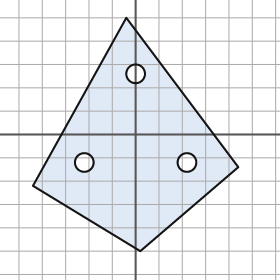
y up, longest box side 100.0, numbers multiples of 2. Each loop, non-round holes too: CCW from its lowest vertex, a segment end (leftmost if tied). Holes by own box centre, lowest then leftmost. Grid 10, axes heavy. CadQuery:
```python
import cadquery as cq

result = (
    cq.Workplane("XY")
    .moveTo(2.0, -50.0)
    .lineTo(44.0, -14.0)
    .lineTo(-4.0, 50.0)
    .lineTo(-44.0, -22.0)
    .close()
    .moveTo(-22.0, -12.0)
    .circle(4.0)
    .moveTo(22.0, -12.0)
    .circle(4.0)
    .moveTo(0.0, 26.0)
    .circle(4.0)
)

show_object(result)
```